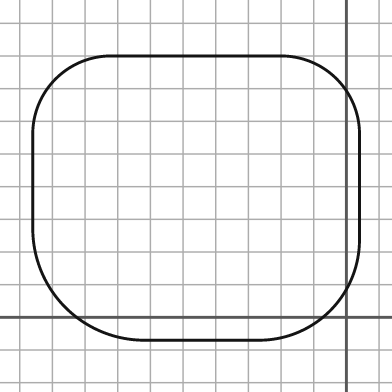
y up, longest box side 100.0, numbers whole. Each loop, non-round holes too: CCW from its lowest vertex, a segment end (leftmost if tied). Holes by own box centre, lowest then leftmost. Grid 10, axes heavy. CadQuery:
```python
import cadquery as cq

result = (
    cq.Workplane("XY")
    .moveTo(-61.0, -7.0)
    .lineTo(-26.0, -7.0)
    .threePointArc((-5.0, 2.0), (4.0, 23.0))
    .lineTo(4.0, 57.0)
    .threePointArc((-3.0, 73.0), (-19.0, 80.0))
    .lineTo(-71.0, 80.0)
    .threePointArc((-89.0, 73.0), (-96.0, 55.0))
    .lineTo(-96.0, 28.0)
    .threePointArc((-86.0, 3.0), (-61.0, -7.0))
    .close()
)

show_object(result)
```